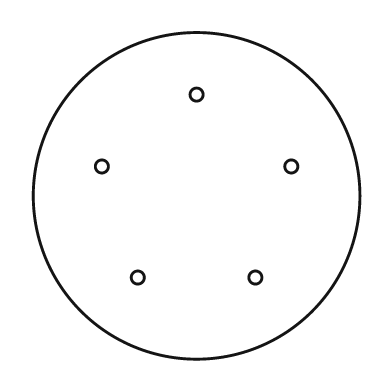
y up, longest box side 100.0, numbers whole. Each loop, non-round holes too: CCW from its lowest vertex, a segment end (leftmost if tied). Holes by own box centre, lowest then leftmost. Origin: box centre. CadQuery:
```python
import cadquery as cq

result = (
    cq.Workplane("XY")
    .moveTo(0.0, 0.0)
    .circle(50.0)
    .moveTo(-18.0, -25.0)
    .circle(2.0)
    .moveTo(18.0, -25.0)
    .circle(2.0)
    .moveTo(-29.0, 9.0)
    .circle(2.0)
    .moveTo(29.0, 9.0)
    .circle(2.0)
    .moveTo(0.0, 31.0)
    .circle(2.0)
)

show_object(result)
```